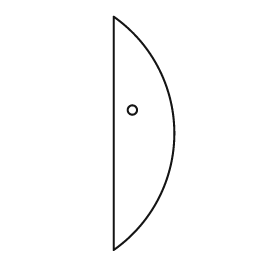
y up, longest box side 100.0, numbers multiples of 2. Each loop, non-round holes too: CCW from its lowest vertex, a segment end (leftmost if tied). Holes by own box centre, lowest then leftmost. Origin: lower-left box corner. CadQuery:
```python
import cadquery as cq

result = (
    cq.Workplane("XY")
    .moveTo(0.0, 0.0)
    .threePointArc((26.0, 50.0), (0.0, 100.0))
    .close()
    .moveTo(8.0, 60.0)
    .circle(2.0)
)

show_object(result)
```